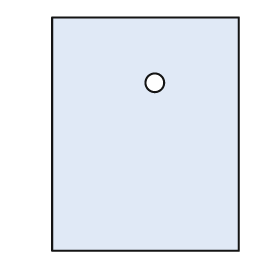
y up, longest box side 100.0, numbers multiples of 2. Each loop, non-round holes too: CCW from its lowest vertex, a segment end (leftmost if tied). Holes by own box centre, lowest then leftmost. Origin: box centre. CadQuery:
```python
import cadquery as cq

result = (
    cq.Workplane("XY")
    .moveTo(-40.0, -50.0)
    .lineTo(40.0, -50.0)
    .lineTo(40.0, 50.0)
    .lineTo(-40.0, 50.0)
    .close()
    .moveTo(4.0, 22.0)
    .circle(4.0)
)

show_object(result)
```